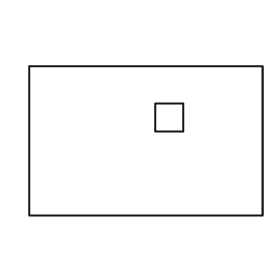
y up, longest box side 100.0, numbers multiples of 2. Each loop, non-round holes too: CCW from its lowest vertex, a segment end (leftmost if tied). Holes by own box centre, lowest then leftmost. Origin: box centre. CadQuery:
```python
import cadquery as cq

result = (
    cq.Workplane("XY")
    .moveTo(-50.0, -32.0)
    .lineTo(50.0, -32.0)
    .lineTo(50.0, 32.0)
    .lineTo(-50.0, 32.0)
    .close()
    .moveTo(4.0, 4.0)
    .lineTo(16.0, 4.0)
    .lineTo(16.0, 16.0)
    .lineTo(4.0, 16.0)
    .close()
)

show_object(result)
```